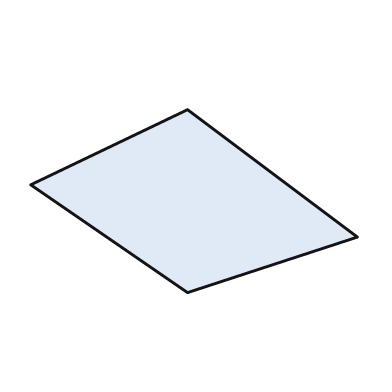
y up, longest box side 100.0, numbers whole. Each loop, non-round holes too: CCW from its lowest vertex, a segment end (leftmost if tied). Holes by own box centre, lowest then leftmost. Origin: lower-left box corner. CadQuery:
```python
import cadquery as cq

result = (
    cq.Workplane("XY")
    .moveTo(48.0, 0.0)
    .lineTo(100.0, 17.0)
    .lineTo(48.0, 56.0)
    .lineTo(0.0, 33.0)
    .close()
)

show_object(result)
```